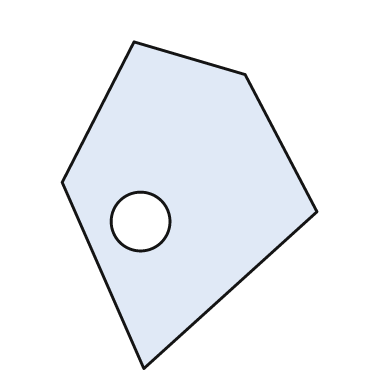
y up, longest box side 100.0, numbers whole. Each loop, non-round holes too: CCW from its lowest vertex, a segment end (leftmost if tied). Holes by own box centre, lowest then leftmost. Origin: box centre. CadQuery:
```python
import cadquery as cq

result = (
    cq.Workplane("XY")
    .moveTo(-14.0, -50.0)
    .lineTo(39.0, -2.0)
    .lineTo(17.0, 40.0)
    .lineTo(-17.0, 50.0)
    .lineTo(-39.0, 7.0)
    .close()
    .moveTo(-15.0, -5.0)
    .circle(9.0)
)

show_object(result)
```